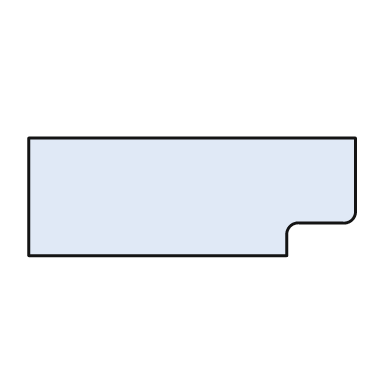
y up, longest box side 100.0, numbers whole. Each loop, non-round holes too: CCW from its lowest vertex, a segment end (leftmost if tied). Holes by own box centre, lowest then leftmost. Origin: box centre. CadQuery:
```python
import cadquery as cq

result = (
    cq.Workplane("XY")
    .moveTo(-50.0, -18.0)
    .lineTo(29.0, -18.0)
    .lineTo(29.0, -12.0)
    .threePointArc((30.0, -9.0), (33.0, -8.0))
    .lineTo(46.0, -8.0)
    .threePointArc((49.0, -7.0), (50.0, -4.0))
    .lineTo(50.0, 18.0)
    .lineTo(-50.0, 18.0)
    .close()
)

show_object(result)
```